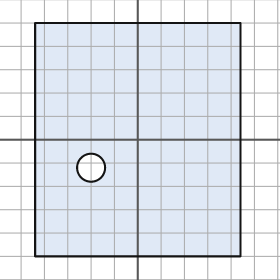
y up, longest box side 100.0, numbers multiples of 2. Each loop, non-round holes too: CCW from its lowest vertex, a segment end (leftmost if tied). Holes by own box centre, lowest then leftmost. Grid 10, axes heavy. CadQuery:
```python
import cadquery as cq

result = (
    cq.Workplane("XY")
    .moveTo(-44.0, -50.0)
    .lineTo(44.0, -50.0)
    .lineTo(44.0, 50.0)
    .lineTo(-44.0, 50.0)
    .close()
    .moveTo(-20.0, -12.0)
    .circle(6.0)
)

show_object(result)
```